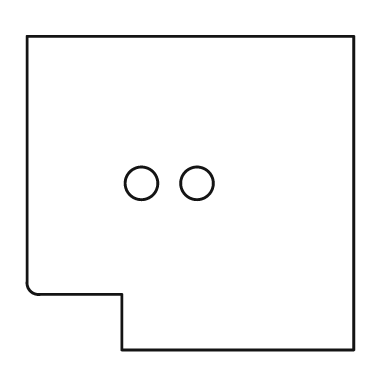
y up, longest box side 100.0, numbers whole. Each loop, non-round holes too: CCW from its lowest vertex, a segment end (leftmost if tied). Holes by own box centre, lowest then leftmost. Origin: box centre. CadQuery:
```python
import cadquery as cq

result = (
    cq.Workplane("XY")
    .moveTo(-21.0, -48.0)
    .lineTo(50.0, -48.0)
    .lineTo(50.0, 48.0)
    .lineTo(-50.0, 48.0)
    .lineTo(-50.0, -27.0)
    .threePointArc((-49.0, -30.0), (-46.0, -31.0))
    .lineTo(-21.0, -31.0)
    .close()
    .moveTo(-15.0, 3.0)
    .circle(5.0)
    .moveTo(2.0, 3.0)
    .circle(5.0)
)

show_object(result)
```